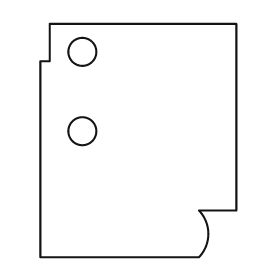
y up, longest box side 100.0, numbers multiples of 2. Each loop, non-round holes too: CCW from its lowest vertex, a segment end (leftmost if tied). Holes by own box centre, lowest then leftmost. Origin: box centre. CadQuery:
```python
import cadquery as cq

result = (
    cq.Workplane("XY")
    .moveTo(-42.0, -50.0)
    .lineTo(26.0, -50.0)
    .threePointArc((30.0, -40.0), (26.0, -30.0))
    .lineTo(42.0, -30.0)
    .lineTo(42.0, 50.0)
    .lineTo(-38.0, 50.0)
    .lineTo(-38.0, 34.0)
    .lineTo(-42.0, 34.0)
    .close()
    .moveTo(-24.0, 4.0)
    .circle(6.0)
    .moveTo(-24.0, 38.0)
    .circle(6.0)
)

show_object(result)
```